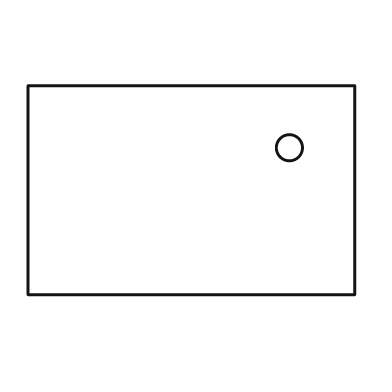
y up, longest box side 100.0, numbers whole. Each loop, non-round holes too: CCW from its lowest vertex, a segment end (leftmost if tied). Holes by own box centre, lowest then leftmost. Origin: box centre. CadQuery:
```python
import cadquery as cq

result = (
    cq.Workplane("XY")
    .moveTo(-50.0, -32.0)
    .lineTo(50.0, -32.0)
    .lineTo(50.0, 32.0)
    .lineTo(-50.0, 32.0)
    .close()
    .moveTo(30.0, 13.0)
    .circle(4.0)
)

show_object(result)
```